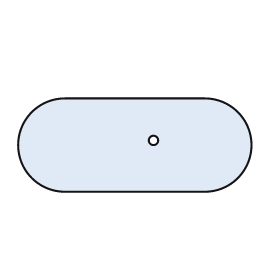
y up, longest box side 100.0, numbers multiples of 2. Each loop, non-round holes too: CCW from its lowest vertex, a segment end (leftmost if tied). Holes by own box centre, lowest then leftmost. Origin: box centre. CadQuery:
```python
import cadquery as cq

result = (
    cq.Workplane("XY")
    .moveTo(-30.0, -20.0)
    .lineTo(30.0, -20.0)
    .threePointArc((50.0, 0.0), (30.0, 20.0))
    .lineTo(-30.0, 20.0)
    .threePointArc((-50.0, 0.0), (-30.0, -20.0))
    .close()
    .moveTo(8.0, 2.0)
    .circle(2.0)
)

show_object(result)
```